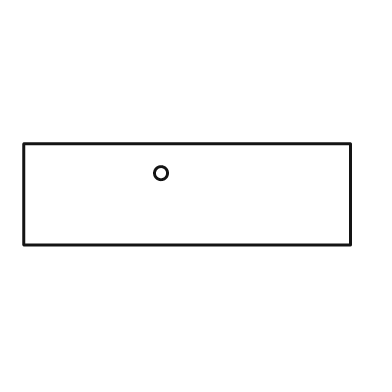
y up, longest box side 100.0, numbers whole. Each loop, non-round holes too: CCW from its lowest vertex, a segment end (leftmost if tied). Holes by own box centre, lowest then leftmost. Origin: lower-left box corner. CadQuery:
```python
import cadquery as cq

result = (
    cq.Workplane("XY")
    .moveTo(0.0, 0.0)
    .lineTo(100.0, 0.0)
    .lineTo(100.0, 31.0)
    .lineTo(0.0, 31.0)
    .close()
    .moveTo(42.0, 22.0)
    .circle(2.0)
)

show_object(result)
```